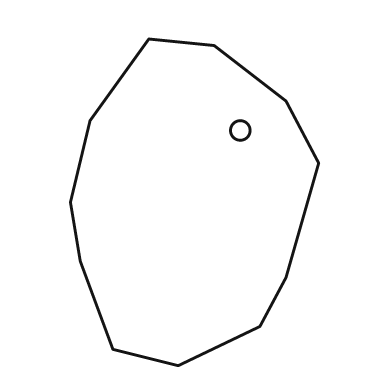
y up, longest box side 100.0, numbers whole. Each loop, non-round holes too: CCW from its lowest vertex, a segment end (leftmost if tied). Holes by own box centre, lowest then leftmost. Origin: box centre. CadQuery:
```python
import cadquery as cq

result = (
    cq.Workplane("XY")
    .moveTo(-5.0, -50.0)
    .lineTo(20.0, -38.0)
    .lineTo(28.0, -23.0)
    .lineTo(38.0, 12.0)
    .lineTo(28.0, 31.0)
    .lineTo(6.0, 48.0)
    .lineTo(-14.0, 50.0)
    .lineTo(-32.0, 25.0)
    .lineTo(-38.0, 0.0)
    .lineTo(-35.0, -18.0)
    .lineTo(-25.0, -45.0)
    .close()
    .moveTo(14.0, 22.0)
    .circle(3.0)
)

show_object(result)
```